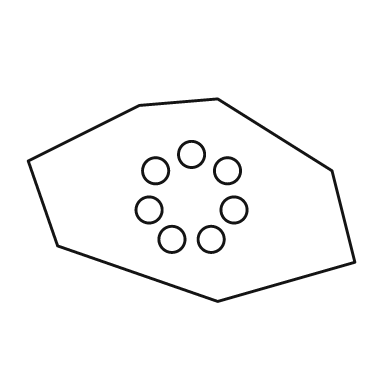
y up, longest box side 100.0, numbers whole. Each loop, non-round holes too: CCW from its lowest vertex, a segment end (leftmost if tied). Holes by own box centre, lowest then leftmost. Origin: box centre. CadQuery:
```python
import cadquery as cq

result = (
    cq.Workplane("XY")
    .moveTo(8.0, -31.0)
    .lineTo(50.0, -19.0)
    .lineTo(43.0, 9.0)
    .lineTo(8.0, 31.0)
    .lineTo(-16.0, 29.0)
    .lineTo(-50.0, 12.0)
    .lineTo(-41.0, -14.0)
    .close()
    .moveTo(-6.0, -12.0)
    .circle(4.0)
    .moveTo(6.0, -12.0)
    .circle(4.0)
    .moveTo(-13.0, -3.0)
    .circle(4.0)
    .moveTo(13.0, -3.0)
    .circle(4.0)
    .moveTo(-11.0, 9.0)
    .circle(4.0)
    .moveTo(11.0, 9.0)
    .circle(4.0)
    .moveTo(0.0, 14.0)
    .circle(4.0)
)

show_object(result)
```